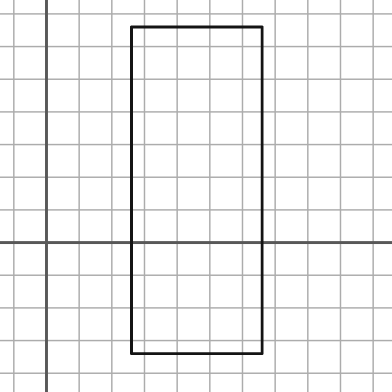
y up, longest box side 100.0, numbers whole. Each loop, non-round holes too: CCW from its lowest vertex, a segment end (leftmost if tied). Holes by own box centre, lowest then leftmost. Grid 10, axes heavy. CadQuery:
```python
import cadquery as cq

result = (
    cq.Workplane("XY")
    .moveTo(26.0, -34.0)
    .lineTo(66.0, -34.0)
    .lineTo(66.0, 66.0)
    .lineTo(26.0, 66.0)
    .close()
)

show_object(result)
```